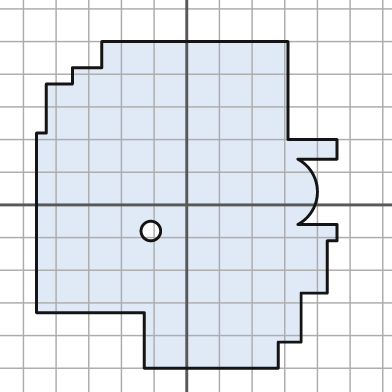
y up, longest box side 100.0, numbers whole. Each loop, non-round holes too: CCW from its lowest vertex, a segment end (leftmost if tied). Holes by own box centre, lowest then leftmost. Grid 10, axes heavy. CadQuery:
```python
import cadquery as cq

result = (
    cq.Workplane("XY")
    .moveTo(-13.0, -50.0)
    .lineTo(28.0, -50.0)
    .lineTo(28.0, -42.0)
    .lineTo(35.0, -42.0)
    .lineTo(35.0, -27.0)
    .lineTo(43.0, -27.0)
    .lineTo(43.0, -11.0)
    .lineTo(46.0, -11.0)
    .lineTo(46.0, -6.0)
    .lineTo(34.0, -6.0)
    .threePointArc((40.0, 4.0), (34.0, 14.0))
    .lineTo(46.0, 14.0)
    .lineTo(46.0, 20.0)
    .lineTo(31.0, 20.0)
    .lineTo(31.0, 50.0)
    .lineTo(-26.0, 50.0)
    .lineTo(-26.0, 42.0)
    .lineTo(-35.0, 42.0)
    .lineTo(-35.0, 37.0)
    .lineTo(-43.0, 37.0)
    .lineTo(-43.0, 22.0)
    .lineTo(-46.0, 22.0)
    .lineTo(-46.0, -33.0)
    .lineTo(-13.0, -33.0)
    .close()
    .moveTo(-11.0, -8.0)
    .circle(3.0)
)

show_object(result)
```